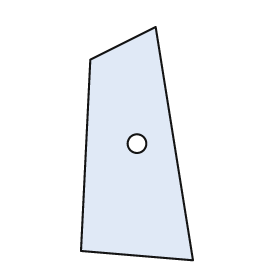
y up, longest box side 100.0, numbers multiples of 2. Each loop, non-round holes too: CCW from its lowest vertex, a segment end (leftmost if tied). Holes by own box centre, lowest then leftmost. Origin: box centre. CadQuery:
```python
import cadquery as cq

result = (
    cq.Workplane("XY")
    .moveTo(24.0, -50.0)
    .lineTo(8.0, 50.0)
    .lineTo(-20.0, 36.0)
    .lineTo(-24.0, -46.0)
    .close()
    .moveTo(0.0, 0.0)
    .circle(4.0)
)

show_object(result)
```